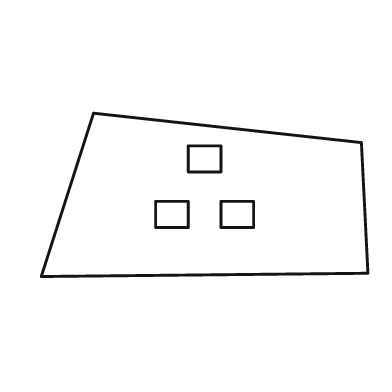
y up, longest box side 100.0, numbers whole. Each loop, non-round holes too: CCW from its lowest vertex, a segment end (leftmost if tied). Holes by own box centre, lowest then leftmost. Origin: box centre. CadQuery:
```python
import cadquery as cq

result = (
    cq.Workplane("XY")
    .moveTo(-50.0, -25.0)
    .lineTo(50.0, -24.0)
    .lineTo(48.0, 16.0)
    .lineTo(-34.0, 25.0)
    .close()
    .moveTo(-15.0, -10.0)
    .lineTo(-5.0, -10.0)
    .lineTo(-5.0, -2.0)
    .lineTo(-15.0, -2.0)
    .close()
    .moveTo(5.0, -10.0)
    .lineTo(15.0, -10.0)
    .lineTo(15.0, -2.0)
    .lineTo(5.0, -2.0)
    .close()
    .moveTo(-5.0, 7.0)
    .lineTo(5.0, 7.0)
    .lineTo(5.0, 15.0)
    .lineTo(-5.0, 15.0)
    .close()
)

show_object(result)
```